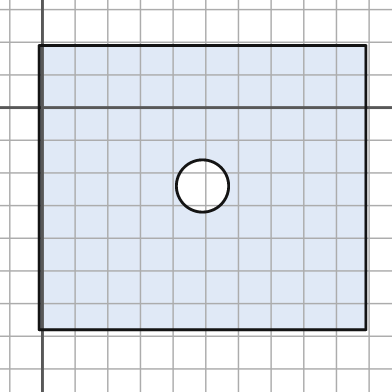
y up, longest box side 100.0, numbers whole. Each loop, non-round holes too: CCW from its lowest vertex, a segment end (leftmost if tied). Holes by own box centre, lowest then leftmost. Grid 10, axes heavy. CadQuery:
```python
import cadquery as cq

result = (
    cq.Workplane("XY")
    .moveTo(-1.0, -68.0)
    .lineTo(99.0, -68.0)
    .lineTo(99.0, 19.0)
    .lineTo(-1.0, 19.0)
    .close()
    .moveTo(49.0, -24.0)
    .circle(8.0)
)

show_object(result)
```